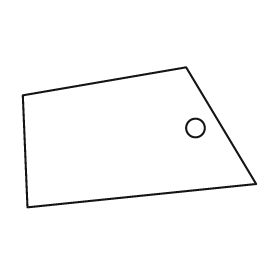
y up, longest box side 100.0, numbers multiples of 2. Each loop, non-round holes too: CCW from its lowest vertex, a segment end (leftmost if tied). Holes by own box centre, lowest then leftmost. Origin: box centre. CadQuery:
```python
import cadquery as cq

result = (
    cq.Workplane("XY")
    .moveTo(-48.0, -30.0)
    .lineTo(50.0, -20.0)
    .lineTo(20.0, 30.0)
    .lineTo(-50.0, 18.0)
    .close()
    .moveTo(24.0, 4.0)
    .circle(4.0)
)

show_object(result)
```